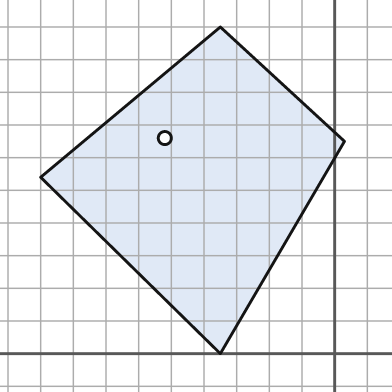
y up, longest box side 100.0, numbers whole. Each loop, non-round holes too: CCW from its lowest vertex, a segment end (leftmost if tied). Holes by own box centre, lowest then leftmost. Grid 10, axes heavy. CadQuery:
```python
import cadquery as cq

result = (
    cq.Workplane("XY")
    .moveTo(-35.0, 0.0)
    .lineTo(3.0, 65.0)
    .lineTo(-35.0, 100.0)
    .lineTo(-90.0, 54.0)
    .close()
    .moveTo(-52.0, 66.0)
    .circle(2.0)
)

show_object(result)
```